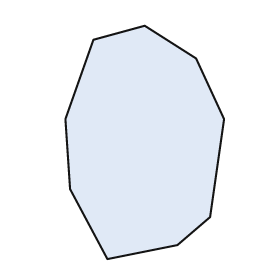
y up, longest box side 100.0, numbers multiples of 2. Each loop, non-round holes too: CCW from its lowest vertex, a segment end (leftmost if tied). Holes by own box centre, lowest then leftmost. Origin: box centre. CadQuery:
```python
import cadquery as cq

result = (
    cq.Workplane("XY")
    .moveTo(-16.0, -50.0)
    .lineTo(14.0, -44.0)
    .lineTo(28.0, -32.0)
    .lineTo(34.0, 10.0)
    .lineTo(22.0, 36.0)
    .lineTo(0.0, 50.0)
    .lineTo(-22.0, 44.0)
    .lineTo(-34.0, 10.0)
    .lineTo(-32.0, -20.0)
    .close()
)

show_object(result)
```